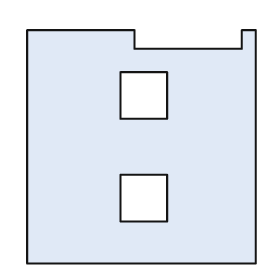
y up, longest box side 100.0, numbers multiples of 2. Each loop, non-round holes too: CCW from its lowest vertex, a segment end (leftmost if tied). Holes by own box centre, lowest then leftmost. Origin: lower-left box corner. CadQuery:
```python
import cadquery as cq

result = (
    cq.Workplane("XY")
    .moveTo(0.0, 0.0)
    .lineTo(98.0, 0.0)
    .lineTo(98.0, 100.0)
    .lineTo(92.0, 100.0)
    .lineTo(92.0, 92.0)
    .lineTo(46.0, 92.0)
    .lineTo(46.0, 100.0)
    .lineTo(0.0, 100.0)
    .close()
    .moveTo(40.0, 18.0)
    .lineTo(60.0, 18.0)
    .lineTo(60.0, 38.0)
    .lineTo(40.0, 38.0)
    .close()
    .moveTo(40.0, 62.0)
    .lineTo(60.0, 62.0)
    .lineTo(60.0, 82.0)
    .lineTo(40.0, 82.0)
    .close()
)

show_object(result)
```